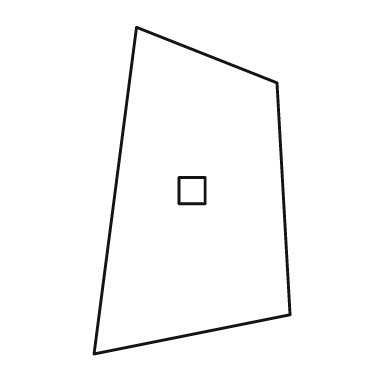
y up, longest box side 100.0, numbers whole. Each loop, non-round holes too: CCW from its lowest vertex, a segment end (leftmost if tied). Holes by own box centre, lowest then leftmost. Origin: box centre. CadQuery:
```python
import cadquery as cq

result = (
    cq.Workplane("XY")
    .moveTo(-30.0, -50.0)
    .lineTo(30.0, -38.0)
    .lineTo(26.0, 33.0)
    .lineTo(-17.0, 50.0)
    .close()
    .moveTo(-4.0, -4.0)
    .lineTo(4.0, -4.0)
    .lineTo(4.0, 4.0)
    .lineTo(-4.0, 4.0)
    .close()
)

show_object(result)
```